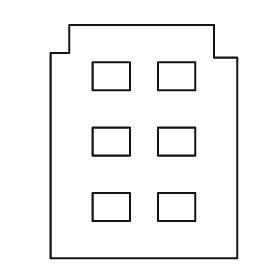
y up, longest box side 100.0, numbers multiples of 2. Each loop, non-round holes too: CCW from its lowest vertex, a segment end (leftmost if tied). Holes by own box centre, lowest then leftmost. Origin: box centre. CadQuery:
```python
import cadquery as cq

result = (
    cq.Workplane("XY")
    .moveTo(-40.0, -50.0)
    .lineTo(40.0, -50.0)
    .lineTo(40.0, 36.0)
    .lineTo(30.0, 36.0)
    .lineTo(30.0, 50.0)
    .lineTo(-32.0, 50.0)
    .lineTo(-32.0, 38.0)
    .lineTo(-40.0, 38.0)
    .close()
    .moveTo(-22.0, -34.0)
    .lineTo(-6.0, -34.0)
    .lineTo(-6.0, -22.0)
    .lineTo(-22.0, -22.0)
    .close()
    .moveTo(6.0, -34.0)
    .lineTo(22.0, -34.0)
    .lineTo(22.0, -22.0)
    .lineTo(6.0, -22.0)
    .close()
    .moveTo(-22.0, -6.0)
    .lineTo(-6.0, -6.0)
    .lineTo(-6.0, 6.0)
    .lineTo(-22.0, 6.0)
    .close()
    .moveTo(6.0, -6.0)
    .lineTo(22.0, -6.0)
    .lineTo(22.0, 6.0)
    .lineTo(6.0, 6.0)
    .close()
    .moveTo(-22.0, 22.0)
    .lineTo(-6.0, 22.0)
    .lineTo(-6.0, 34.0)
    .lineTo(-22.0, 34.0)
    .close()
    .moveTo(6.0, 22.0)
    .lineTo(22.0, 22.0)
    .lineTo(22.0, 34.0)
    .lineTo(6.0, 34.0)
    .close()
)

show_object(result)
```